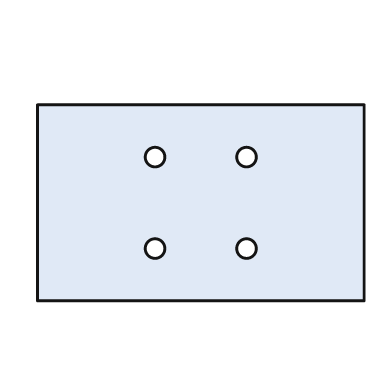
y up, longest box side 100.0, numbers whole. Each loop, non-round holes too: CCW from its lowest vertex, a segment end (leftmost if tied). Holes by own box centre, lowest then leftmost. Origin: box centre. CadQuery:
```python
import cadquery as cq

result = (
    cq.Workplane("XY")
    .moveTo(-50.0, -30.0)
    .lineTo(50.0, -30.0)
    .lineTo(50.0, 30.0)
    .lineTo(-50.0, 30.0)
    .close()
    .moveTo(-14.0, -14.0)
    .circle(3.0)
    .moveTo(14.0, -14.0)
    .circle(3.0)
    .moveTo(-14.0, 14.0)
    .circle(3.0)
    .moveTo(14.0, 14.0)
    .circle(3.0)
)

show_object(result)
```